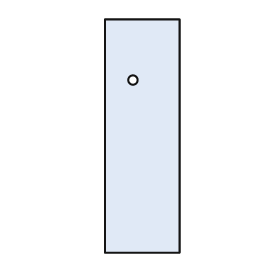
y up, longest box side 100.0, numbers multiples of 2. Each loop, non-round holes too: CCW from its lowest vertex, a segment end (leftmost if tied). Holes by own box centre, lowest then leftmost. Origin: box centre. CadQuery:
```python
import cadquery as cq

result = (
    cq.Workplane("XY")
    .moveTo(-16.0, -50.0)
    .lineTo(16.0, -50.0)
    .lineTo(16.0, 50.0)
    .lineTo(-16.0, 50.0)
    .close()
    .moveTo(-4.0, 24.0)
    .circle(2.0)
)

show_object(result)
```